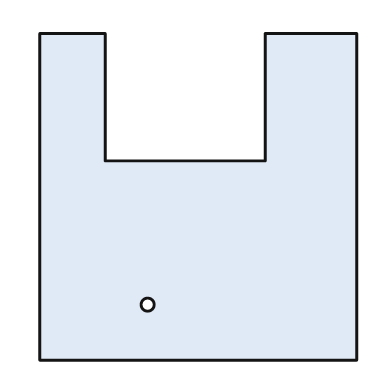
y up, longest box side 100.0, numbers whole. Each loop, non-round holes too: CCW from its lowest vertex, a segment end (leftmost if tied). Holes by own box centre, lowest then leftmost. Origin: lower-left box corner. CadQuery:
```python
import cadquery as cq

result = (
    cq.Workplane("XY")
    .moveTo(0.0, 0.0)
    .lineTo(97.0, 0.0)
    .lineTo(97.0, 100.0)
    .lineTo(69.0, 100.0)
    .lineTo(69.0, 61.0)
    .lineTo(20.0, 61.0)
    .lineTo(20.0, 100.0)
    .lineTo(0.0, 100.0)
    .close()
    .moveTo(33.0, 17.0)
    .circle(2.0)
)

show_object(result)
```